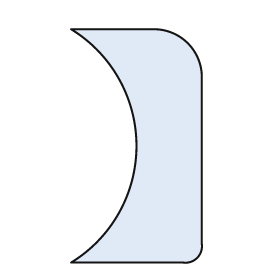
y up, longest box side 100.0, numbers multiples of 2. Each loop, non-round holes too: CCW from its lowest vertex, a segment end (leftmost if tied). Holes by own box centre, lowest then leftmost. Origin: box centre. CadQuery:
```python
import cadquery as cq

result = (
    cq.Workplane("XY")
    .moveTo(-28.0, -50.0)
    .lineTo(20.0, -50.0)
    .threePointArc((26.0, -48.0), (28.0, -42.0))
    .lineTo(28.0, 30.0)
    .threePointArc((22.0, 44.0), (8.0, 50.0))
    .lineTo(-28.0, 50.0)
    .threePointArc((0.0, 0.0), (-28.0, -50.0))
    .close()
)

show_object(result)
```